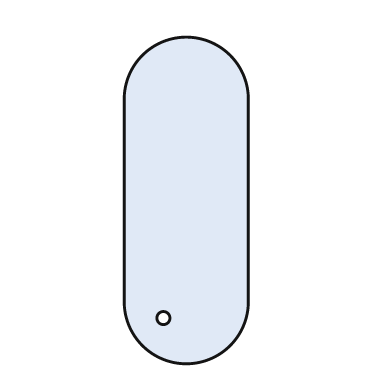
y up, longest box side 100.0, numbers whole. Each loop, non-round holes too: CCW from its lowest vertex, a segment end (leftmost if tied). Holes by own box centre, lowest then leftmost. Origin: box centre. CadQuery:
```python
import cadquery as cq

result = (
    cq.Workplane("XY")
    .moveTo(-19.0, -31.0)
    .threePointArc((0.0, -50.0), (19.0, -31.0))
    .lineTo(19.0, 31.0)
    .threePointArc((0.0, 50.0), (-19.0, 31.0))
    .close()
    .moveTo(-7.0, -36.0)
    .circle(2.0)
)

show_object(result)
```